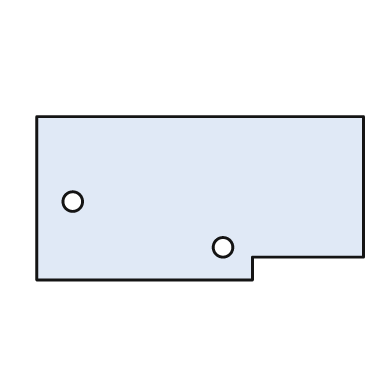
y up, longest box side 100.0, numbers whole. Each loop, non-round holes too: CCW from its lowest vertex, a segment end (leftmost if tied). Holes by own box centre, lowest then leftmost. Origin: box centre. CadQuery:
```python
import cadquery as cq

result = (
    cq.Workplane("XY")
    .moveTo(-50.0, -25.0)
    .lineTo(16.0, -25.0)
    .lineTo(16.0, -18.0)
    .lineTo(50.0, -18.0)
    .lineTo(50.0, 25.0)
    .lineTo(-50.0, 25.0)
    .close()
    .moveTo(7.0, -15.0)
    .circle(3.0)
    .moveTo(-39.0, -1.0)
    .circle(3.0)
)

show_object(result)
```